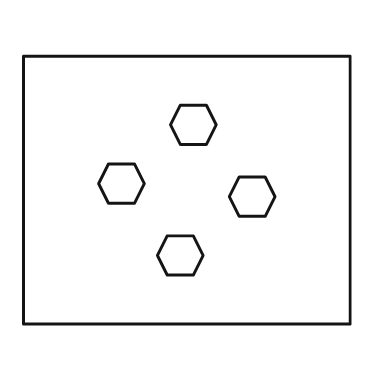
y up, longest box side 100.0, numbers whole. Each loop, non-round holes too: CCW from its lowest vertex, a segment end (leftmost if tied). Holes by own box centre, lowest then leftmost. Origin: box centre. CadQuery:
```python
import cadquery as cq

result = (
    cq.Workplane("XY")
    .moveTo(-50.0, -41.0)
    .lineTo(50.0, -41.0)
    .lineTo(50.0, 41.0)
    .lineTo(-50.0, 41.0)
    .close()
    .moveTo(-6.0, -26.0)
    .lineTo(2.0, -26.0)
    .lineTo(5.0, -20.0)
    .lineTo(2.0, -14.0)
    .lineTo(-6.0, -14.0)
    .lineTo(-9.0, -20.0)
    .close()
    .moveTo(16.0, -8.0)
    .lineTo(24.0, -8.0)
    .lineTo(27.0, -2.0)
    .lineTo(24.0, 4.0)
    .lineTo(16.0, 4.0)
    .lineTo(13.0, -2.0)
    .close()
    .moveTo(-24.0, -4.0)
    .lineTo(-16.0, -4.0)
    .lineTo(-13.0, 2.0)
    .lineTo(-16.0, 8.0)
    .lineTo(-24.0, 8.0)
    .lineTo(-27.0, 2.0)
    .close()
    .moveTo(-2.0, 14.0)
    .lineTo(6.0, 14.0)
    .lineTo(9.0, 20.0)
    .lineTo(6.0, 26.0)
    .lineTo(-2.0, 26.0)
    .lineTo(-5.0, 20.0)
    .close()
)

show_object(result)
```